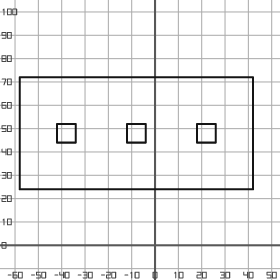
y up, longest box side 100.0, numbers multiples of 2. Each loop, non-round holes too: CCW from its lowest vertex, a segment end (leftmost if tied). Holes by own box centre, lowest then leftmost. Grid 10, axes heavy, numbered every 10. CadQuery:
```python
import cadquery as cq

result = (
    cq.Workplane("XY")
    .moveTo(-58.0, 24.0)
    .lineTo(42.0, 24.0)
    .lineTo(42.0, 72.0)
    .lineTo(-58.0, 72.0)
    .close()
    .moveTo(-42.0, 44.0)
    .lineTo(-34.0, 44.0)
    .lineTo(-34.0, 52.0)
    .lineTo(-42.0, 52.0)
    .close()
    .moveTo(-12.0, 44.0)
    .lineTo(-4.0, 44.0)
    .lineTo(-4.0, 52.0)
    .lineTo(-12.0, 52.0)
    .close()
    .moveTo(18.0, 44.0)
    .lineTo(26.0, 44.0)
    .lineTo(26.0, 52.0)
    .lineTo(18.0, 52.0)
    .close()
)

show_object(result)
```